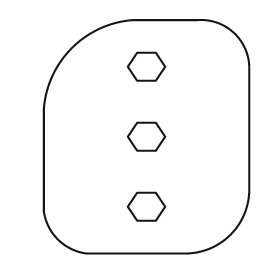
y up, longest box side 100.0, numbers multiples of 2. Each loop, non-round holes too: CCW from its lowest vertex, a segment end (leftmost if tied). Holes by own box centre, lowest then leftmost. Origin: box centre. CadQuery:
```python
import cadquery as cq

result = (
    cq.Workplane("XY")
    .moveTo(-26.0, -50.0)
    .lineTo(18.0, -50.0)
    .threePointArc((36.0, -42.0), (44.0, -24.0))
    .lineTo(44.0, 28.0)
    .threePointArc((38.0, 44.0), (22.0, 50.0))
    .lineTo(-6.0, 50.0)
    .threePointArc((-32.0, 38.0), (-44.0, 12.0))
    .lineTo(-44.0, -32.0)
    .threePointArc((-38.0, -44.0), (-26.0, -50.0))
    .close()
    .moveTo(-4.0, -36.0)
    .lineTo(4.0, -36.0)
    .lineTo(8.0, -30.0)
    .lineTo(4.0, -24.0)
    .lineTo(-4.0, -24.0)
    .lineTo(-8.0, -30.0)
    .close()
    .moveTo(-4.0, -6.0)
    .lineTo(4.0, -6.0)
    .lineTo(8.0, 0.0)
    .lineTo(4.0, 6.0)
    .lineTo(-4.0, 6.0)
    .lineTo(-8.0, 0.0)
    .close()
    .moveTo(-4.0, 24.0)
    .lineTo(4.0, 24.0)
    .lineTo(8.0, 30.0)
    .lineTo(4.0, 36.0)
    .lineTo(-4.0, 36.0)
    .lineTo(-8.0, 30.0)
    .close()
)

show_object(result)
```